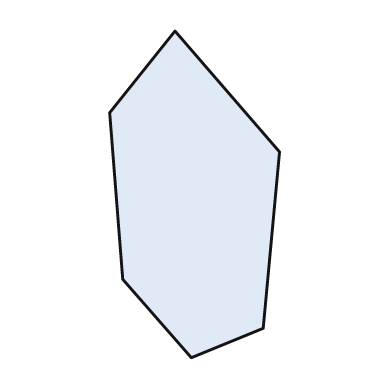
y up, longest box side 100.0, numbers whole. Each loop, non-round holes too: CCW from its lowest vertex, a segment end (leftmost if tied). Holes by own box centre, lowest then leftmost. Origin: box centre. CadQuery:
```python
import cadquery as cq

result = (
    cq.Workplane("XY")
    .moveTo(-1.0, -50.0)
    .lineTo(21.0, -41.0)
    .lineTo(26.0, 13.0)
    .lineTo(-6.0, 50.0)
    .lineTo(-26.0, 25.0)
    .lineTo(-22.0, -26.0)
    .close()
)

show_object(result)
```